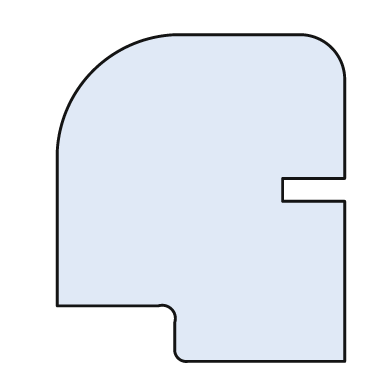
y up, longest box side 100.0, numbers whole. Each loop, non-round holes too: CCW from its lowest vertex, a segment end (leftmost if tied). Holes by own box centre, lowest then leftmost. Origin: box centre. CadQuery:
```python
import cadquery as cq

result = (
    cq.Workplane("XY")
    .moveTo(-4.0, -50.0)
    .lineTo(44.0, -50.0)
    .lineTo(44.0, -1.0)
    .lineTo(25.0, -1.0)
    .lineTo(25.0, 6.0)
    .lineTo(44.0, 6.0)
    .lineTo(44.0, 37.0)
    .threePointArc((40.0, 46.0), (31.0, 50.0))
    .lineTo(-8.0, 50.0)
    .threePointArc((-33.0, 39.0), (-44.0, 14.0))
    .lineTo(-44.0, -33.0)
    .lineTo(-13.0, -33.0)
    .threePointArc((-9.0, -34.0), (-8.0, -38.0))
    .lineTo(-8.0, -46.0)
    .threePointArc((-7.0, -49.0), (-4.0, -50.0))
    .close()
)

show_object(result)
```